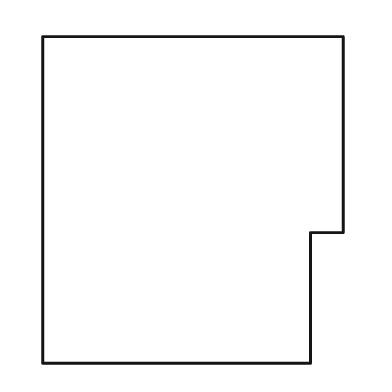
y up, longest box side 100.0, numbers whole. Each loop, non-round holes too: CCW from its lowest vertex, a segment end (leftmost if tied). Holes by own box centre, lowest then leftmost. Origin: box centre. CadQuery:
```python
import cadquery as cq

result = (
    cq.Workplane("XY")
    .moveTo(-46.0, -50.0)
    .lineTo(36.0, -50.0)
    .lineTo(36.0, -10.0)
    .lineTo(46.0, -10.0)
    .lineTo(46.0, 50.0)
    .lineTo(-46.0, 50.0)
    .close()
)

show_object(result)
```